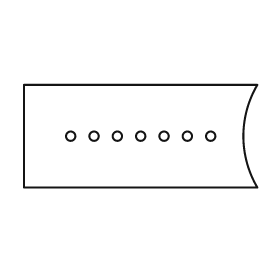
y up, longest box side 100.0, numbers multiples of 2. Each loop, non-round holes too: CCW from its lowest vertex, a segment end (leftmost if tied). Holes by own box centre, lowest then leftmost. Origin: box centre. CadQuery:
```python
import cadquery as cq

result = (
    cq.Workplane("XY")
    .moveTo(-50.0, -22.0)
    .lineTo(50.0, -22.0)
    .threePointArc((44.0, 0.0), (50.0, 22.0))
    .lineTo(-50.0, 22.0)
    .close()
    .moveTo(-30.0, 0.0)
    .circle(2.0)
    .moveTo(-20.0, 0.0)
    .circle(2.0)
    .moveTo(-10.0, 0.0)
    .circle(2.0)
    .moveTo(0.0, 0.0)
    .circle(2.0)
    .moveTo(10.0, 0.0)
    .circle(2.0)
    .moveTo(20.0, 0.0)
    .circle(2.0)
    .moveTo(30.0, 0.0)
    .circle(2.0)
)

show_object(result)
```